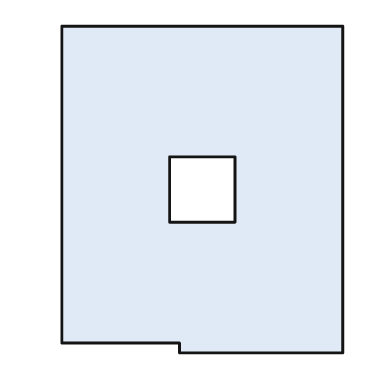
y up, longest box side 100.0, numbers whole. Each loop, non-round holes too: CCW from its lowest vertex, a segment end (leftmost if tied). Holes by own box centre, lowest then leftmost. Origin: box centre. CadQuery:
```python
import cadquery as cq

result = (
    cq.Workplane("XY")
    .moveTo(-7.0, -50.0)
    .lineTo(43.0, -50.0)
    .lineTo(43.0, 50.0)
    .lineTo(-43.0, 50.0)
    .lineTo(-43.0, -47.0)
    .lineTo(-7.0, -47.0)
    .close()
    .moveTo(-10.0, -10.0)
    .lineTo(10.0, -10.0)
    .lineTo(10.0, 10.0)
    .lineTo(-10.0, 10.0)
    .close()
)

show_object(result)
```